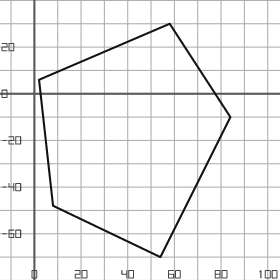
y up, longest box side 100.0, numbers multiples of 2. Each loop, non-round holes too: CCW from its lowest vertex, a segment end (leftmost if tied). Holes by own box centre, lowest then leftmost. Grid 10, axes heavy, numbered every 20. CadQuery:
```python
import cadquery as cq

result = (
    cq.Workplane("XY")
    .moveTo(54.0, -70.0)
    .lineTo(84.0, -10.0)
    .lineTo(58.0, 30.0)
    .lineTo(2.0, 6.0)
    .lineTo(8.0, -48.0)
    .close()
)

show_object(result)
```